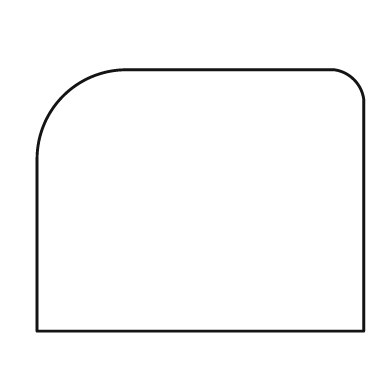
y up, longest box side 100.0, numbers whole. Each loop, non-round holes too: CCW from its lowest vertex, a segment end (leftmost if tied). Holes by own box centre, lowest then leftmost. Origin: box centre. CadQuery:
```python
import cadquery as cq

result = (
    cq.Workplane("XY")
    .moveTo(-50.0, -40.0)
    .lineTo(50.0, -40.0)
    .lineTo(50.0, 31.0)
    .threePointArc((47.0, 37.0), (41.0, 40.0))
    .lineTo(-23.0, 40.0)
    .threePointArc((-42.0, 32.0), (-50.0, 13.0))
    .close()
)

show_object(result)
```